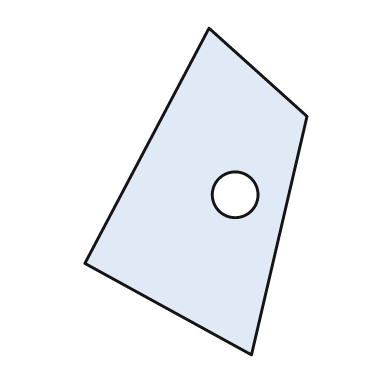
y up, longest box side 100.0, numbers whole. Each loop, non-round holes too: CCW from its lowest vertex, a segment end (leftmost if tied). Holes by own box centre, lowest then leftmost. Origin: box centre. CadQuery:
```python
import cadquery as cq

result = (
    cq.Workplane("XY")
    .moveTo(17.0, -50.0)
    .lineTo(34.0, 23.0)
    .lineTo(4.0, 50.0)
    .lineTo(-34.0, -22.0)
    .close()
    .moveTo(12.0, -1.0)
    .circle(7.0)
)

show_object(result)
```